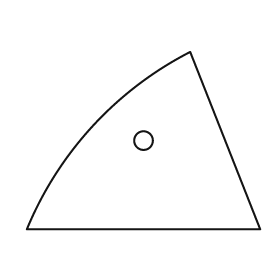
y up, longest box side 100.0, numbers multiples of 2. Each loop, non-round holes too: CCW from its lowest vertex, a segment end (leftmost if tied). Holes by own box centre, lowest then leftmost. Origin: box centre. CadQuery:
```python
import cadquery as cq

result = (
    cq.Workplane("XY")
    .moveTo(-50.0, -38.0)
    .lineTo(50.0, -38.0)
    .lineTo(20.0, 38.0)
    .threePointArc((-22.0, 6.0), (-50.0, -38.0))
    .close()
    .moveTo(0.0, 0.0)
    .circle(4.0)
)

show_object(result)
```